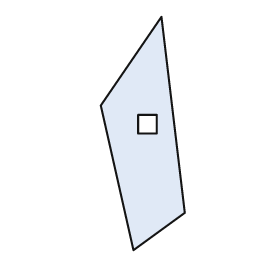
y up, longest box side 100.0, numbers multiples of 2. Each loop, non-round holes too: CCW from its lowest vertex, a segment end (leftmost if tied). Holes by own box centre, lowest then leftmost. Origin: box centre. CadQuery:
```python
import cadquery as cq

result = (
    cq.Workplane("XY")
    .moveTo(-4.0, -50.0)
    .lineTo(18.0, -34.0)
    .lineTo(8.0, 50.0)
    .lineTo(-18.0, 12.0)
    .close()
    .moveTo(-2.0, 0.0)
    .lineTo(6.0, 0.0)
    .lineTo(6.0, 8.0)
    .lineTo(-2.0, 8.0)
    .close()
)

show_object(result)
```